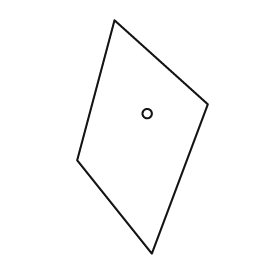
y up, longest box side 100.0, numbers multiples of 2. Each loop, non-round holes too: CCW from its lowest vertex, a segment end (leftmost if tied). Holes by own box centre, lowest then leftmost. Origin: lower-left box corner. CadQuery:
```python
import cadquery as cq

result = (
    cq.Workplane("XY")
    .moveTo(32.0, 0.0)
    .lineTo(56.0, 64.0)
    .lineTo(16.0, 100.0)
    .lineTo(0.0, 40.0)
    .close()
    .moveTo(30.0, 60.0)
    .circle(2.0)
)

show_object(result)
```